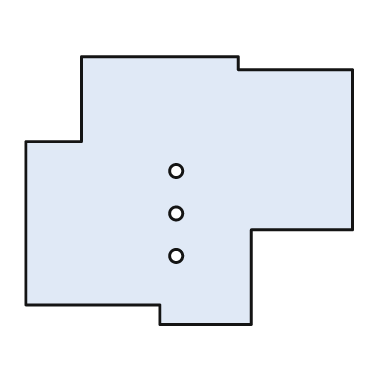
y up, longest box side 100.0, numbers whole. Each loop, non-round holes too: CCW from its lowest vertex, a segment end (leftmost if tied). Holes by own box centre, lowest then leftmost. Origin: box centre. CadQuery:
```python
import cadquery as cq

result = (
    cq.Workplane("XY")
    .moveTo(-9.0, -41.0)
    .lineTo(19.0, -41.0)
    .lineTo(19.0, -12.0)
    .lineTo(50.0, -12.0)
    .lineTo(50.0, 37.0)
    .lineTo(15.0, 37.0)
    .lineTo(15.0, 41.0)
    .lineTo(-33.0, 41.0)
    .lineTo(-33.0, 15.0)
    .lineTo(-50.0, 15.0)
    .lineTo(-50.0, -35.0)
    .lineTo(-9.0, -35.0)
    .close()
    .moveTo(-4.0, -20.0)
    .circle(2.0)
    .moveTo(-4.0, -7.0)
    .circle(2.0)
    .moveTo(-4.0, 6.0)
    .circle(2.0)
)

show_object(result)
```